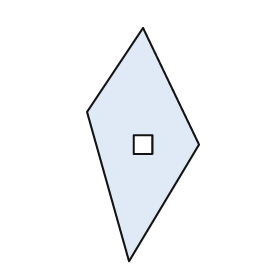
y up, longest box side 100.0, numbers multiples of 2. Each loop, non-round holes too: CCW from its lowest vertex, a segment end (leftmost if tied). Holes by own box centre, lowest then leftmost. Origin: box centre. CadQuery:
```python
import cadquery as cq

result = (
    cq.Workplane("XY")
    .moveTo(-6.0, -50.0)
    .lineTo(24.0, 0.0)
    .lineTo(0.0, 50.0)
    .lineTo(-24.0, 14.0)
    .close()
    .moveTo(-4.0, -4.0)
    .lineTo(4.0, -4.0)
    .lineTo(4.0, 4.0)
    .lineTo(-4.0, 4.0)
    .close()
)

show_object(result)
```